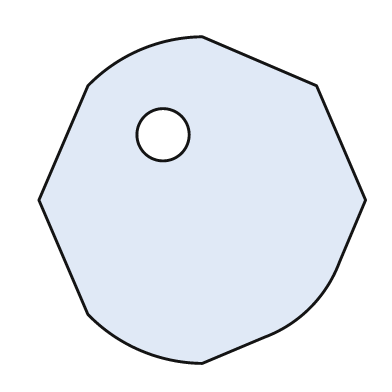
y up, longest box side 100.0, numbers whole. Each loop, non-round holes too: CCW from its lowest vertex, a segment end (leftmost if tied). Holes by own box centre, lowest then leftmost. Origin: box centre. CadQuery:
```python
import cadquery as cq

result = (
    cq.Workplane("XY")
    .moveTo(0.0, -50.0)
    .lineTo(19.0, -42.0)
    .threePointArc((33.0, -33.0), (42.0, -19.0))
    .lineTo(50.0, 0.0)
    .lineTo(35.0, 35.0)
    .lineTo(0.0, 50.0)
    .threePointArc((-19.0, 46.0), (-35.0, 35.0))
    .lineTo(-50.0, 0.0)
    .lineTo(-35.0, -35.0)
    .threePointArc((-19.0, -46.0), (0.0, -50.0))
    .close()
    .moveTo(-12.0, 20.0)
    .circle(8.0)
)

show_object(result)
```